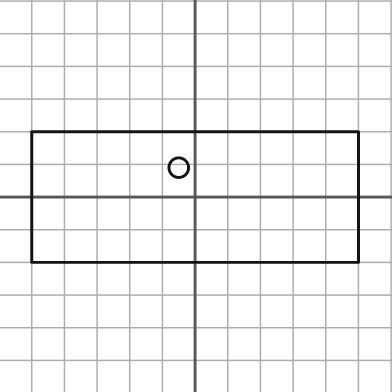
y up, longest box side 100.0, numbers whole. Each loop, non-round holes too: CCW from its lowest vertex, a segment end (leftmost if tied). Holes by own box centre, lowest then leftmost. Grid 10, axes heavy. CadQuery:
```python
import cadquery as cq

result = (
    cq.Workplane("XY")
    .moveTo(-50.0, -20.0)
    .lineTo(50.0, -20.0)
    .lineTo(50.0, 20.0)
    .lineTo(-50.0, 20.0)
    .close()
    .moveTo(-5.0, 9.0)
    .circle(3.0)
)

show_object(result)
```